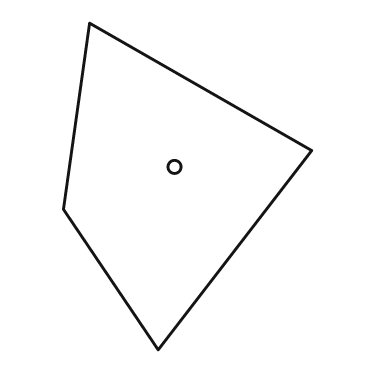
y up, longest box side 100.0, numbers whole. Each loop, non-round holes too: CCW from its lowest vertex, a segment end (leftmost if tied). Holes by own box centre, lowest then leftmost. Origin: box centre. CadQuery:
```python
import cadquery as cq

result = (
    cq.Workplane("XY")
    .moveTo(-9.0, -50.0)
    .lineTo(38.0, 11.0)
    .lineTo(-30.0, 50.0)
    .lineTo(-38.0, -7.0)
    .close()
    .moveTo(-4.0, 6.0)
    .circle(2.0)
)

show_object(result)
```